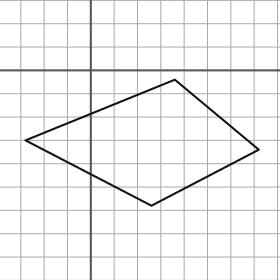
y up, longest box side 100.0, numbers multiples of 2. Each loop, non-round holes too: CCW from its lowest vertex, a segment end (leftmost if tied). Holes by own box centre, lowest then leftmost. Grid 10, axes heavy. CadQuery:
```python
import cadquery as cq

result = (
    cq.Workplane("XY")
    .moveTo(26.0, -58.0)
    .lineTo(72.0, -34.0)
    .lineTo(36.0, -4.0)
    .lineTo(-28.0, -30.0)
    .close()
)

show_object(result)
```